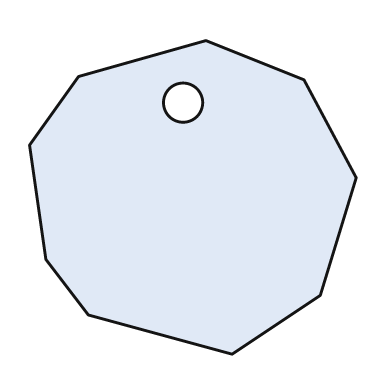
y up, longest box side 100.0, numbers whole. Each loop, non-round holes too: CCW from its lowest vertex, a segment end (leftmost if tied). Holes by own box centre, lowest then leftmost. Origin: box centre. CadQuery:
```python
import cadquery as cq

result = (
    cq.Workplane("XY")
    .moveTo(12.0, -48.0)
    .lineTo(39.0, -30.0)
    .lineTo(50.0, 6.0)
    .lineTo(34.0, 36.0)
    .lineTo(4.0, 48.0)
    .lineTo(-35.0, 37.0)
    .lineTo(-50.0, 16.0)
    .lineTo(-45.0, -19.0)
    .lineTo(-32.0, -36.0)
    .close()
    .moveTo(-3.0, 29.0)
    .circle(6.0)
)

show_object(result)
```